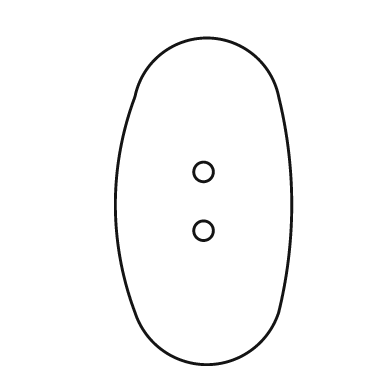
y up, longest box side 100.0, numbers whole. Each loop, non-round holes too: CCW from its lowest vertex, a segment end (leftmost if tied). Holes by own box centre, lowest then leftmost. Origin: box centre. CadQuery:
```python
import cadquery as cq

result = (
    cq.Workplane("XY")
    .moveTo(-21.0, -34.0)
    .threePointArc((1.0, -50.0), (23.0, -34.0))
    .threePointArc((27.0, -1.0), (23.0, 32.0))
    .threePointArc((1.0, 50.0), (-21.0, 32.0))
    .threePointArc((-27.0, -1.0), (-21.0, -34.0))
    .close()
    .moveTo(0.0, -9.0)
    .circle(3.0)
    .moveTo(0.0, 9.0)
    .circle(3.0)
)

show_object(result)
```